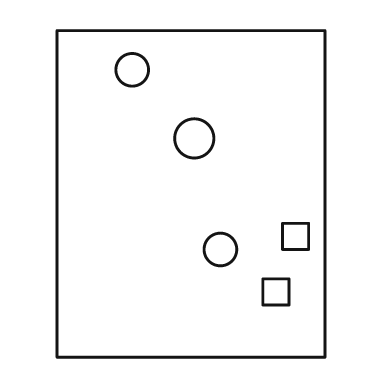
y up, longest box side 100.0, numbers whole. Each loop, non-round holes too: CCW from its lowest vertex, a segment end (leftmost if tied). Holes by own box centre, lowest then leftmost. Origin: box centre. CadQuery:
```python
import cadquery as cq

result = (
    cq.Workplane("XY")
    .moveTo(-41.0, -50.0)
    .lineTo(41.0, -50.0)
    .lineTo(41.0, 50.0)
    .lineTo(-41.0, 50.0)
    .close()
    .moveTo(22.0, -34.0)
    .lineTo(30.0, -34.0)
    .lineTo(30.0, -26.0)
    .lineTo(22.0, -26.0)
    .close()
    .moveTo(9.0, -17.0)
    .circle(5.0)
    .moveTo(28.0, -17.0)
    .lineTo(36.0, -17.0)
    .lineTo(36.0, -9.0)
    .lineTo(28.0, -9.0)
    .close()
    .moveTo(1.0, 17.0)
    .circle(6.0)
    .moveTo(-18.0, 38.0)
    .circle(5.0)
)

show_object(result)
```